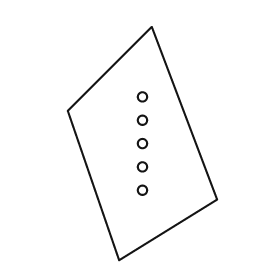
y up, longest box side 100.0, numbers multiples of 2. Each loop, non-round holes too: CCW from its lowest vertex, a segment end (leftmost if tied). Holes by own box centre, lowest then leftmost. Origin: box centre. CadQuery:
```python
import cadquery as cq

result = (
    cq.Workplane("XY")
    .moveTo(-10.0, -50.0)
    .lineTo(32.0, -24.0)
    .lineTo(4.0, 50.0)
    .lineTo(-32.0, 14.0)
    .close()
    .moveTo(0.0, -20.0)
    .circle(2.0)
    .moveTo(0.0, -10.0)
    .circle(2.0)
    .moveTo(0.0, 0.0)
    .circle(2.0)
    .moveTo(0.0, 10.0)
    .circle(2.0)
    .moveTo(0.0, 20.0)
    .circle(2.0)
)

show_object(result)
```